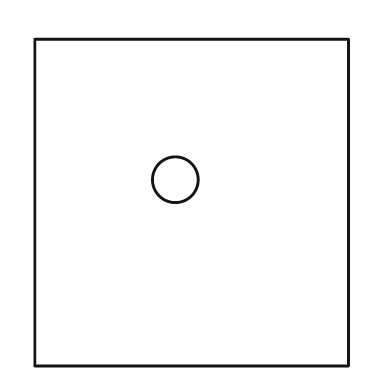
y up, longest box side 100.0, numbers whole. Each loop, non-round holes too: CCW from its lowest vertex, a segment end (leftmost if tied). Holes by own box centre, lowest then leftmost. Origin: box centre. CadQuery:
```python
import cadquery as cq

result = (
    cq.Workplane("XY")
    .moveTo(-48.0, -50.0)
    .lineTo(48.0, -50.0)
    .lineTo(48.0, 50.0)
    .lineTo(-48.0, 50.0)
    .close()
    .moveTo(-5.0, 7.0)
    .circle(7.0)
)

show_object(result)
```